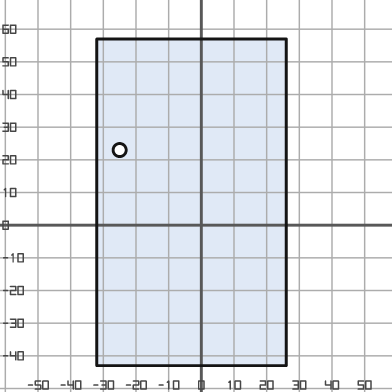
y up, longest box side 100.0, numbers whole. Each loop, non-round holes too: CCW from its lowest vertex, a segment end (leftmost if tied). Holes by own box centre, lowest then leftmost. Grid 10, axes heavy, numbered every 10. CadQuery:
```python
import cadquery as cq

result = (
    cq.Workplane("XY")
    .moveTo(-32.0, -43.0)
    .lineTo(26.0, -43.0)
    .lineTo(26.0, 57.0)
    .lineTo(-32.0, 57.0)
    .close()
    .moveTo(-25.0, 23.0)
    .circle(2.0)
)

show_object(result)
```